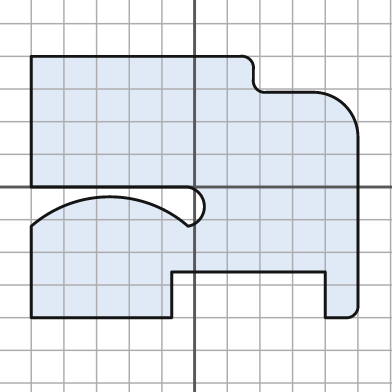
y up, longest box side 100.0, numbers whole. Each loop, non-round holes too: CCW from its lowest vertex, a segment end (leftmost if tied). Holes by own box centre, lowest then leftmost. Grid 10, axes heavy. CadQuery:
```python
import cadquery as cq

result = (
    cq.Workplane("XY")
    .moveTo(-50.0, -40.0)
    .lineTo(-7.0, -40.0)
    .lineTo(-7.0, -26.0)
    .lineTo(40.0, -26.0)
    .lineTo(40.0, -40.0)
    .lineTo(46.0, -40.0)
    .threePointArc((49.0, -39.0), (50.0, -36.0))
    .lineTo(50.0, 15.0)
    .threePointArc((46.0, 25.0), (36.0, 29.0))
    .lineTo(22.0, 29.0)
    .threePointArc((19.0, 30.0), (18.0, 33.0))
    .lineTo(18.0, 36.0)
    .threePointArc((17.0, 39.0), (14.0, 40.0))
    .lineTo(-50.0, 40.0)
    .lineTo(-50.0, 0.0)
    .lineTo(-2.0, 0.0)
    .threePointArc((3.0, -6.0), (-2.0, -12.0))
    .threePointArc((-26.0, -3.0), (-50.0, -12.0))
    .close()
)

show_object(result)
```